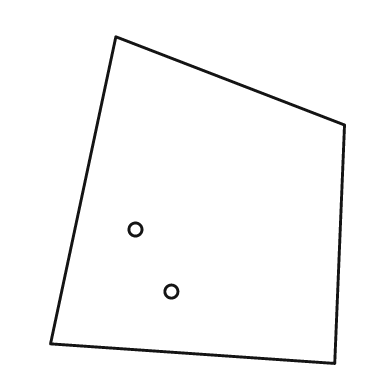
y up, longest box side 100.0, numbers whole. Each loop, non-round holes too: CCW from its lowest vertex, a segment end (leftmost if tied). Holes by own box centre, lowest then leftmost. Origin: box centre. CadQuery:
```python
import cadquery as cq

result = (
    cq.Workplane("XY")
    .moveTo(42.0, -50.0)
    .lineTo(45.0, 23.0)
    .lineTo(-25.0, 50.0)
    .lineTo(-45.0, -44.0)
    .close()
    .moveTo(-8.0, -28.0)
    .circle(2.0)
    .moveTo(-19.0, -9.0)
    .circle(2.0)
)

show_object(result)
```